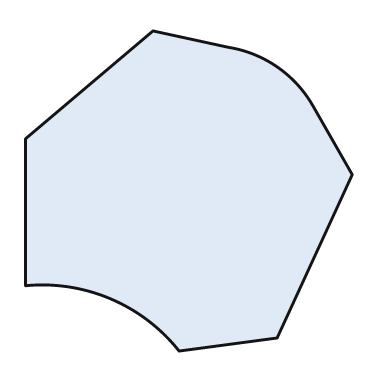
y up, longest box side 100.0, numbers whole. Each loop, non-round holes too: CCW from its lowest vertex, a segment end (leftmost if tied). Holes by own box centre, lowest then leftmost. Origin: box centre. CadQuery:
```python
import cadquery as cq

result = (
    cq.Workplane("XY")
    .moveTo(-3.0, -49.0)
    .lineTo(27.0, -45.0)
    .lineTo(50.0, 5.0)
    .lineTo(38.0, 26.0)
    .threePointArc((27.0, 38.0), (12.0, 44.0))
    .lineTo(-11.0, 49.0)
    .lineTo(-50.0, 16.0)
    .lineTo(-50.0, -29.0)
    .threePointArc((-24.0, -33.0), (-3.0, -49.0))
    .close()
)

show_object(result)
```